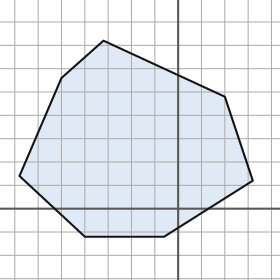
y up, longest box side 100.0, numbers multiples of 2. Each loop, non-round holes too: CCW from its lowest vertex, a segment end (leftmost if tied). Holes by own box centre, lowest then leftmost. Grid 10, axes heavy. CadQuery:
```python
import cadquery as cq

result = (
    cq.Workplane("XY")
    .moveTo(-40.0, -12.0)
    .lineTo(-6.0, -12.0)
    .lineTo(32.0, 12.0)
    .lineTo(20.0, 48.0)
    .lineTo(-32.0, 72.0)
    .lineTo(-50.0, 56.0)
    .lineTo(-68.0, 14.0)
    .close()
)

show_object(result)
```